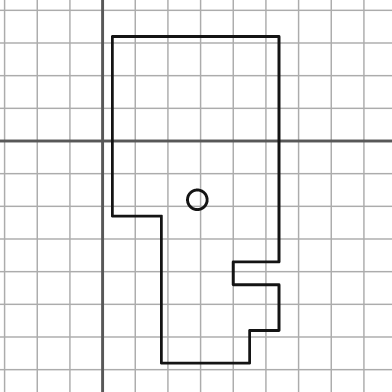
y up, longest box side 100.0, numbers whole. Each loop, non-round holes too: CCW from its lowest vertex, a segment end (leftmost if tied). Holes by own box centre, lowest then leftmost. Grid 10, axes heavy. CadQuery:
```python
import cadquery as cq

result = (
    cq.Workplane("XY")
    .moveTo(18.0, -68.0)
    .lineTo(45.0, -68.0)
    .lineTo(45.0, -58.0)
    .lineTo(54.0, -58.0)
    .lineTo(54.0, -44.0)
    .lineTo(40.0, -44.0)
    .lineTo(40.0, -37.0)
    .lineTo(54.0, -37.0)
    .lineTo(54.0, 32.0)
    .lineTo(3.0, 32.0)
    .lineTo(3.0, -23.0)
    .lineTo(18.0, -23.0)
    .close()
    .moveTo(29.0, -18.0)
    .circle(3.0)
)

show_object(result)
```